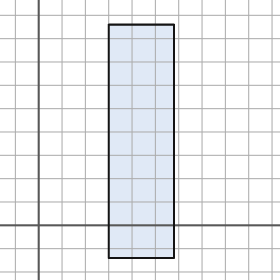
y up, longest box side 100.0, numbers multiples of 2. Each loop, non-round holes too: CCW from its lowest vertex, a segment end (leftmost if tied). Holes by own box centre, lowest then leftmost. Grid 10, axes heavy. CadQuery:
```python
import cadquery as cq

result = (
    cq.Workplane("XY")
    .moveTo(30.0, -14.0)
    .lineTo(58.0, -14.0)
    .lineTo(58.0, 86.0)
    .lineTo(30.0, 86.0)
    .close()
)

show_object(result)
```